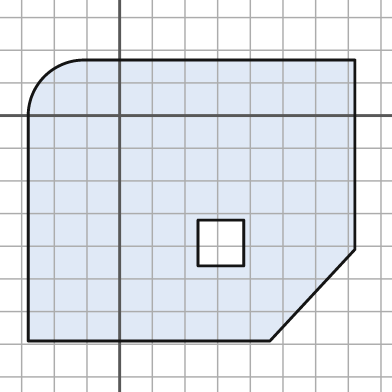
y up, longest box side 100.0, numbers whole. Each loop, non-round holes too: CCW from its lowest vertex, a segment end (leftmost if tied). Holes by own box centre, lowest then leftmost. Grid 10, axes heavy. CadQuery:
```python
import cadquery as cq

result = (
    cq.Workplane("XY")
    .moveTo(-28.0, -69.0)
    .lineTo(46.0, -69.0)
    .lineTo(72.0, -41.0)
    .lineTo(72.0, 17.0)
    .lineTo(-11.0, 17.0)
    .threePointArc((-23.0, 12.0), (-28.0, 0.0))
    .close()
    .moveTo(24.0, -46.0)
    .lineTo(38.0, -46.0)
    .lineTo(38.0, -32.0)
    .lineTo(24.0, -32.0)
    .close()
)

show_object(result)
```